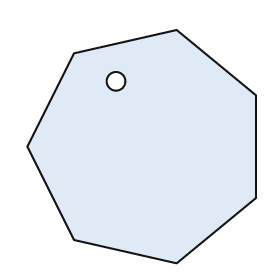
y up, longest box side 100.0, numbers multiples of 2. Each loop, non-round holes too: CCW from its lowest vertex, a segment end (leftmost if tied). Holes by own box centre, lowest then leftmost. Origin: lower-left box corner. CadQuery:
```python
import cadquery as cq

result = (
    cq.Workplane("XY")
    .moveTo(64.0, 0.0)
    .lineTo(98.0, 28.0)
    .lineTo(98.0, 72.0)
    .lineTo(64.0, 100.0)
    .lineTo(20.0, 90.0)
    .lineTo(0.0, 50.0)
    .lineTo(20.0, 10.0)
    .close()
    .moveTo(38.0, 78.0)
    .circle(4.0)
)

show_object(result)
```